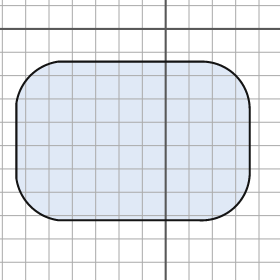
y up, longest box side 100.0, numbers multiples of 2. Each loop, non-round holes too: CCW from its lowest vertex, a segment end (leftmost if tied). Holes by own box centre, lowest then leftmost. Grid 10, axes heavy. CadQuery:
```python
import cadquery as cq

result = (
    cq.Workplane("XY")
    .moveTo(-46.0, -82.0)
    .lineTo(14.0, -82.0)
    .threePointArc((30.0, -76.0), (36.0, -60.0))
    .lineTo(36.0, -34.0)
    .threePointArc((30.0, -20.0), (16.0, -14.0))
    .lineTo(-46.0, -14.0)
    .threePointArc((-58.0, -20.0), (-64.0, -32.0))
    .lineTo(-64.0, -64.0)
    .threePointArc((-58.0, -76.0), (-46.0, -82.0))
    .close()
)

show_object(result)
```